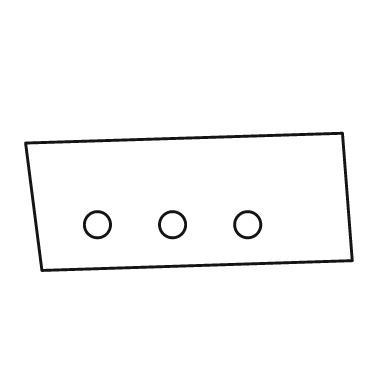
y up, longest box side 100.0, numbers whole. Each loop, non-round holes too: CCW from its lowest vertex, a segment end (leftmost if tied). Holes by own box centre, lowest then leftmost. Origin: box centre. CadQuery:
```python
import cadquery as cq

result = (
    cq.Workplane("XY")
    .moveTo(-45.0, -21.0)
    .lineTo(50.0, -18.0)
    .lineTo(47.0, 21.0)
    .lineTo(-50.0, 18.0)
    .close()
    .moveTo(-28.0, -7.0)
    .circle(4.0)
    .moveTo(-5.0, -7.0)
    .circle(4.0)
    .moveTo(18.0, -7.0)
    .circle(4.0)
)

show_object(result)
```